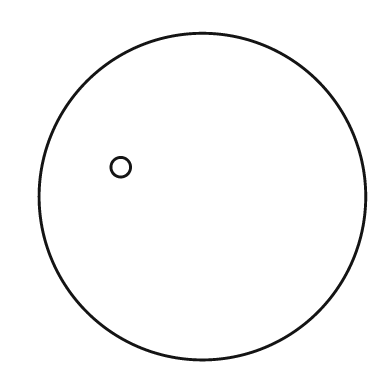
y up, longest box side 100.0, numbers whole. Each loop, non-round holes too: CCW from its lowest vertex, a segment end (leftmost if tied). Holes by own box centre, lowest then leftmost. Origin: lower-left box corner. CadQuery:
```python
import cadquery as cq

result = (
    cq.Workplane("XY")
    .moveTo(50.0, 50.0)
    .circle(50.0)
    .moveTo(25.0, 59.0)
    .circle(3.0)
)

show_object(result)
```